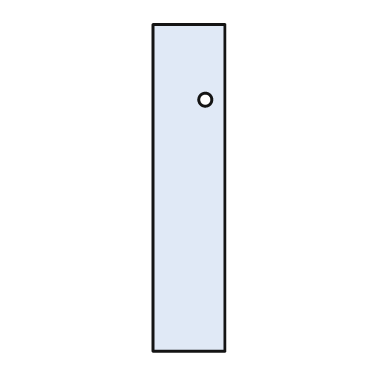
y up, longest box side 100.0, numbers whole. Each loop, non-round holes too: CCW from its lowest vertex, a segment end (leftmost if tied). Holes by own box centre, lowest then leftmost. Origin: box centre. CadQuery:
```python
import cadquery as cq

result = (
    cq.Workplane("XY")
    .moveTo(-11.0, -50.0)
    .lineTo(11.0, -50.0)
    .lineTo(11.0, 50.0)
    .lineTo(-11.0, 50.0)
    .close()
    .moveTo(5.0, 27.0)
    .circle(2.0)
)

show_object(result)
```